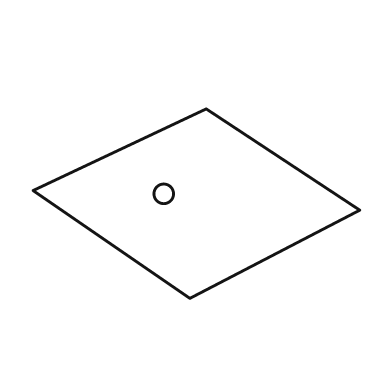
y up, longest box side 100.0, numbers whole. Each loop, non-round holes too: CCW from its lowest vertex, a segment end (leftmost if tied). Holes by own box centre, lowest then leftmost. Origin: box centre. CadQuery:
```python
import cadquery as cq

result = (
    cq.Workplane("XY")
    .moveTo(-2.0, -29.0)
    .lineTo(50.0, -2.0)
    .lineTo(3.0, 29.0)
    .lineTo(-50.0, 4.0)
    .close()
    .moveTo(-10.0, 3.0)
    .circle(3.0)
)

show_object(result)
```